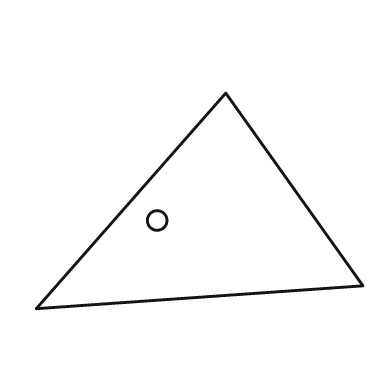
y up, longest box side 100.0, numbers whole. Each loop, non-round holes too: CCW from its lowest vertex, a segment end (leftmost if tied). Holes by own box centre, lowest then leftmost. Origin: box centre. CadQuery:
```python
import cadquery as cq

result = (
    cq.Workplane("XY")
    .moveTo(-50.0, -33.0)
    .lineTo(50.0, -26.0)
    .lineTo(8.0, 33.0)
    .close()
    .moveTo(-13.0, -6.0)
    .circle(3.0)
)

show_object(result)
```